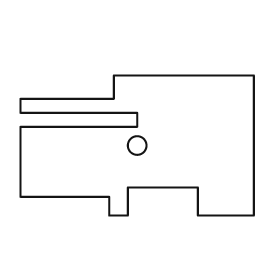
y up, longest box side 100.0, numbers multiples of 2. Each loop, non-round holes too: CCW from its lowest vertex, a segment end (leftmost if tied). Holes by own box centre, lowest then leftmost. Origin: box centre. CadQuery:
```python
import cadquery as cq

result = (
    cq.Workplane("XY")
    .moveTo(-12.0, -30.0)
    .lineTo(-4.0, -30.0)
    .lineTo(-4.0, -18.0)
    .lineTo(26.0, -18.0)
    .lineTo(26.0, -30.0)
    .lineTo(50.0, -30.0)
    .lineTo(50.0, 30.0)
    .lineTo(-10.0, 30.0)
    .lineTo(-10.0, 20.0)
    .lineTo(-50.0, 20.0)
    .lineTo(-50.0, 14.0)
    .lineTo(0.0, 14.0)
    .lineTo(0.0, 8.0)
    .lineTo(-50.0, 8.0)
    .lineTo(-50.0, -22.0)
    .lineTo(-12.0, -22.0)
    .close()
    .moveTo(0.0, 0.0)
    .circle(4.0)
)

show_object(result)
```